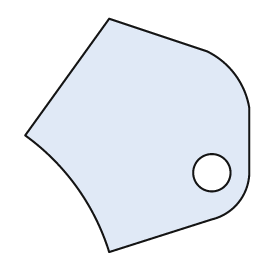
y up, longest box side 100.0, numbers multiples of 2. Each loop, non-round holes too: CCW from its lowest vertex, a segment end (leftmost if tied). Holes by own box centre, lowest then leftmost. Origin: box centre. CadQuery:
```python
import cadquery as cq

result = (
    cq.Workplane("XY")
    .moveTo(-12.0, -50.0)
    .lineTo(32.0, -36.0)
    .threePointArc((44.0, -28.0), (48.0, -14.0))
    .lineTo(48.0, 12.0)
    .threePointArc((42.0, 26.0), (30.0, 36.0))
    .lineTo(-12.0, 50.0)
    .lineTo(-48.0, 0.0)
    .threePointArc((-26.0, -22.0), (-12.0, -50.0))
    .close()
    .moveTo(32.0, -16.0)
    .circle(8.0)
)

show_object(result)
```